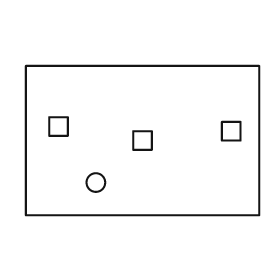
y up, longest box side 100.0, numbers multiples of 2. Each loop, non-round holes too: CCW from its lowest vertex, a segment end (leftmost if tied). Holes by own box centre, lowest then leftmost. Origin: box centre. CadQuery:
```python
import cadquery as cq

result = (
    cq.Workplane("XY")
    .moveTo(-50.0, -32.0)
    .lineTo(50.0, -32.0)
    .lineTo(50.0, 32.0)
    .lineTo(-50.0, 32.0)
    .close()
    .moveTo(-20.0, -18.0)
    .circle(4.0)
    .moveTo(-4.0, -4.0)
    .lineTo(4.0, -4.0)
    .lineTo(4.0, 4.0)
    .lineTo(-4.0, 4.0)
    .close()
    .moveTo(34.0, 0.0)
    .lineTo(42.0, 0.0)
    .lineTo(42.0, 8.0)
    .lineTo(34.0, 8.0)
    .close()
    .moveTo(-40.0, 2.0)
    .lineTo(-32.0, 2.0)
    .lineTo(-32.0, 10.0)
    .lineTo(-40.0, 10.0)
    .close()
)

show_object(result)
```